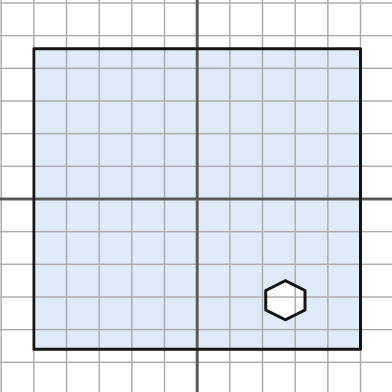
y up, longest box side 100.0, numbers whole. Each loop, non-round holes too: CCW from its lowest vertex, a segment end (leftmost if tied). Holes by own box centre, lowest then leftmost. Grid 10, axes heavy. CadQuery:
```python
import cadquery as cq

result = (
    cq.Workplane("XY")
    .moveTo(-50.0, -46.0)
    .lineTo(50.0, -46.0)
    .lineTo(50.0, 46.0)
    .lineTo(-50.0, 46.0)
    .close()
    .moveTo(27.0, -37.0)
    .lineTo(33.0, -34.0)
    .lineTo(33.0, -28.0)
    .lineTo(27.0, -25.0)
    .lineTo(21.0, -28.0)
    .lineTo(21.0, -34.0)
    .close()
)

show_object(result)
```